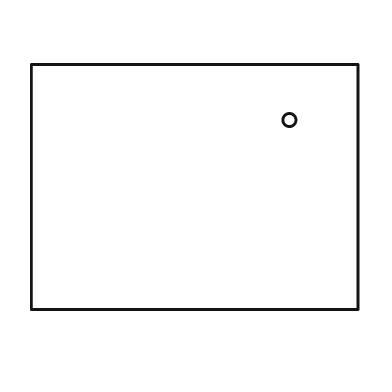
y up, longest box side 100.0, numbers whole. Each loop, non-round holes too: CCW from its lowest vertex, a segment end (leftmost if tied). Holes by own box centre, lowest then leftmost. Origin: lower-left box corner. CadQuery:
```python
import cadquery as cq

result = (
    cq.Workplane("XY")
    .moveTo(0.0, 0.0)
    .lineTo(100.0, 0.0)
    .lineTo(100.0, 75.0)
    .lineTo(0.0, 75.0)
    .close()
    .moveTo(79.0, 58.0)
    .circle(2.0)
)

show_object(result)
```